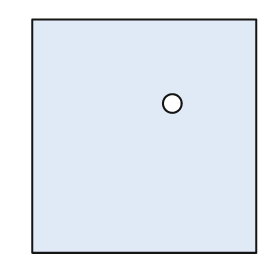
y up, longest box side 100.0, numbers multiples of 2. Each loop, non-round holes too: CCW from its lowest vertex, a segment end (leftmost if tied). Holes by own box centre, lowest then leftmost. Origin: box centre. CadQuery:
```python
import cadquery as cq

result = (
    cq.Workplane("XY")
    .moveTo(-48.0, -50.0)
    .lineTo(48.0, -50.0)
    .lineTo(48.0, 50.0)
    .lineTo(-48.0, 50.0)
    .close()
    .moveTo(12.0, 14.0)
    .circle(4.0)
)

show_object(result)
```